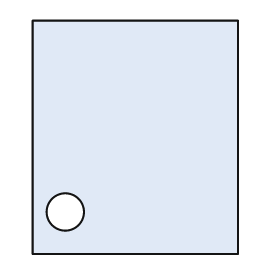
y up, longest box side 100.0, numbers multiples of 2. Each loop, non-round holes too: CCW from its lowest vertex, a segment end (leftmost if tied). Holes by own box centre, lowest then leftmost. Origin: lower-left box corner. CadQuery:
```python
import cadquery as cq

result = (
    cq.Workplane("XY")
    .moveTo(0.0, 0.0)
    .lineTo(88.0, 0.0)
    .lineTo(88.0, 100.0)
    .lineTo(0.0, 100.0)
    .close()
    .moveTo(14.0, 18.0)
    .circle(8.0)
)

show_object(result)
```